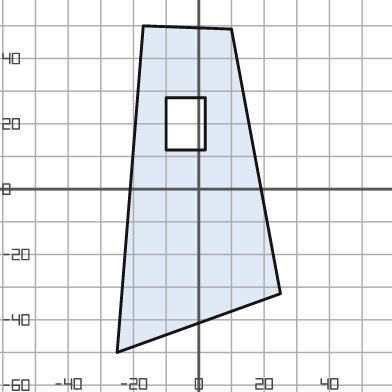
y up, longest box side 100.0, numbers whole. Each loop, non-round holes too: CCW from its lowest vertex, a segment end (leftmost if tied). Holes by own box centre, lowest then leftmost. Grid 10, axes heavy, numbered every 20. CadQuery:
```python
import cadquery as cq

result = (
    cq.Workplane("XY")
    .moveTo(-25.0, -50.0)
    .lineTo(25.0, -32.0)
    .lineTo(10.0, 49.0)
    .lineTo(-17.0, 50.0)
    .close()
    .moveTo(-10.0, 12.0)
    .lineTo(2.0, 12.0)
    .lineTo(2.0, 28.0)
    .lineTo(-10.0, 28.0)
    .close()
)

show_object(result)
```